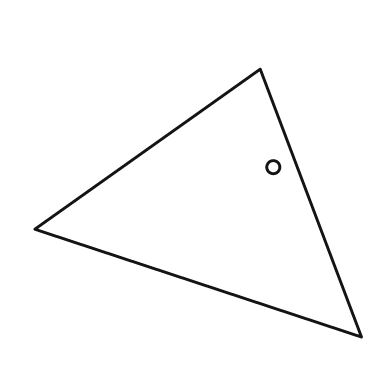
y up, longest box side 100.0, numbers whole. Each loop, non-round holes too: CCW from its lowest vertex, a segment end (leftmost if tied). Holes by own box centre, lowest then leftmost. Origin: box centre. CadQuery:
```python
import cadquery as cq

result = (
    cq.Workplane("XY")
    .moveTo(50.0, -41.0)
    .lineTo(19.0, 41.0)
    .lineTo(-50.0, -8.0)
    .close()
    .moveTo(23.0, 11.0)
    .circle(2.0)
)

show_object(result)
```